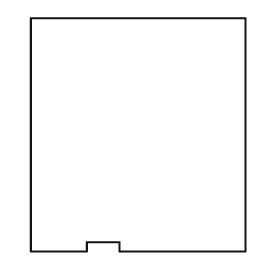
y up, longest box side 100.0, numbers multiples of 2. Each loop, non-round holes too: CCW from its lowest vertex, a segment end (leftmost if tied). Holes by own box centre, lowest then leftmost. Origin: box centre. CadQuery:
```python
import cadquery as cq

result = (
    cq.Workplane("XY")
    .moveTo(-46.0, -50.0)
    .lineTo(-22.0, -50.0)
    .lineTo(-22.0, -46.0)
    .lineTo(-8.0, -46.0)
    .lineTo(-8.0, -50.0)
    .lineTo(46.0, -50.0)
    .lineTo(46.0, 50.0)
    .lineTo(-46.0, 50.0)
    .close()
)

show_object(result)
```